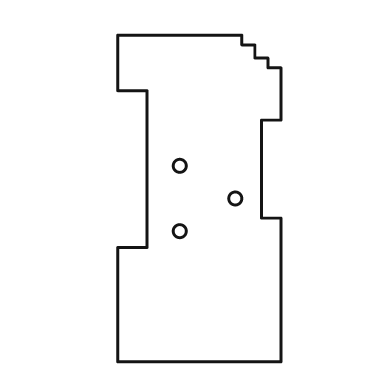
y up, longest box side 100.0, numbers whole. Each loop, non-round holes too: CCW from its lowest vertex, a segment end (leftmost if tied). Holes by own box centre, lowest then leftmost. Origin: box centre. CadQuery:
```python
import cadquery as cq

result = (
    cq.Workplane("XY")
    .moveTo(-25.0, -50.0)
    .lineTo(25.0, -50.0)
    .lineTo(25.0, -6.0)
    .lineTo(19.0, -6.0)
    .lineTo(19.0, 24.0)
    .lineTo(25.0, 24.0)
    .lineTo(25.0, 40.0)
    .lineTo(21.0, 40.0)
    .lineTo(21.0, 43.0)
    .lineTo(17.0, 43.0)
    .lineTo(17.0, 47.0)
    .lineTo(13.0, 47.0)
    .lineTo(13.0, 50.0)
    .lineTo(-25.0, 50.0)
    .lineTo(-25.0, 33.0)
    .lineTo(-16.0, 33.0)
    .lineTo(-16.0, -15.0)
    .lineTo(-25.0, -15.0)
    .close()
    .moveTo(-6.0, -10.0)
    .circle(2.0)
    .moveTo(11.0, 0.0)
    .circle(2.0)
    .moveTo(-6.0, 10.0)
    .circle(2.0)
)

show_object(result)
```